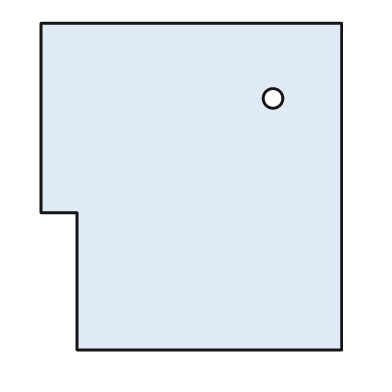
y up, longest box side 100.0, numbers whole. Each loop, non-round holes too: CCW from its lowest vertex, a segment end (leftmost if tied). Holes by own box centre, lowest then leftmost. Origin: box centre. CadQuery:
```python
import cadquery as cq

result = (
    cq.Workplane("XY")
    .moveTo(-35.0, -50.0)
    .lineTo(46.0, -50.0)
    .lineTo(46.0, 50.0)
    .lineTo(-46.0, 50.0)
    .lineTo(-46.0, -8.0)
    .lineTo(-35.0, -8.0)
    .close()
    .moveTo(25.0, 27.0)
    .circle(3.0)
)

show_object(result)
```